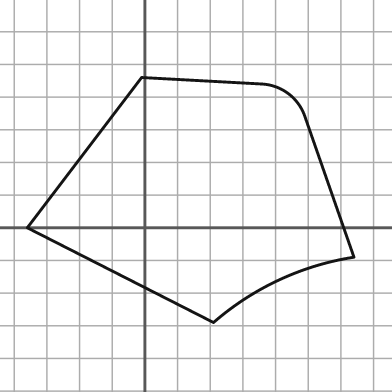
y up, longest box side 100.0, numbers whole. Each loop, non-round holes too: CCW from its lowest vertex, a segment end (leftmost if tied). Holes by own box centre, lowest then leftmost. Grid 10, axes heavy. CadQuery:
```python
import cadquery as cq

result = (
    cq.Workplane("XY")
    .moveTo(21.0, -29.0)
    .threePointArc((41.0, -16.0), (64.0, -9.0))
    .lineTo(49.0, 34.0)
    .threePointArc((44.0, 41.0), (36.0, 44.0))
    .lineTo(-1.0, 46.0)
    .lineTo(-36.0, 0.0)
    .close()
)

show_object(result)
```